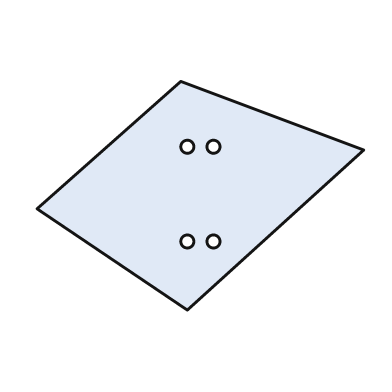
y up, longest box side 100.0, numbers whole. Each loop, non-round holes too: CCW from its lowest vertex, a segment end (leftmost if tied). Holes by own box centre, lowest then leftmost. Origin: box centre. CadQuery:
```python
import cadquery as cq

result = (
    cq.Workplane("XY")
    .moveTo(-4.0, -35.0)
    .lineTo(50.0, 14.0)
    .lineTo(-6.0, 35.0)
    .lineTo(-50.0, -4.0)
    .close()
    .moveTo(-4.0, -14.0)
    .circle(2.0)
    .moveTo(4.0, -14.0)
    .circle(2.0)
    .moveTo(-4.0, 15.0)
    .circle(2.0)
    .moveTo(4.0, 15.0)
    .circle(2.0)
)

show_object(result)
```